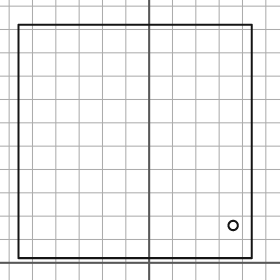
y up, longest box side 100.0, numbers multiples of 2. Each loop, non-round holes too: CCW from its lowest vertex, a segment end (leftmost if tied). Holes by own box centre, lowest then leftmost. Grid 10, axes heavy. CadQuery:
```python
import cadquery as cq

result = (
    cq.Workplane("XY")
    .moveTo(-56.0, 2.0)
    .lineTo(44.0, 2.0)
    .lineTo(44.0, 102.0)
    .lineTo(-56.0, 102.0)
    .close()
    .moveTo(36.0, 16.0)
    .circle(2.0)
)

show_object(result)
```